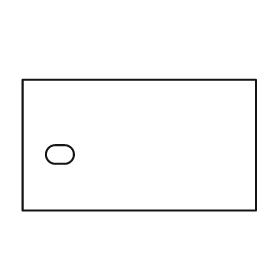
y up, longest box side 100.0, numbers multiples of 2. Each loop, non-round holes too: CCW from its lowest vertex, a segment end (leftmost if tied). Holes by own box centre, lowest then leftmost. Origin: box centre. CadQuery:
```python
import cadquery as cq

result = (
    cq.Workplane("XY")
    .moveTo(-50.0, -28.0)
    .lineTo(50.0, -28.0)
    .lineTo(50.0, 28.0)
    .lineTo(-50.0, 28.0)
    .close()
    .moveTo(-36.0, -8.0)
    .lineTo(-32.0, -8.0)
    .threePointArc((-28.0, -4.0), (-32.0, 0.0))
    .lineTo(-36.0, 0.0)
    .threePointArc((-40.0, -4.0), (-36.0, -8.0))
    .close()
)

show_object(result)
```